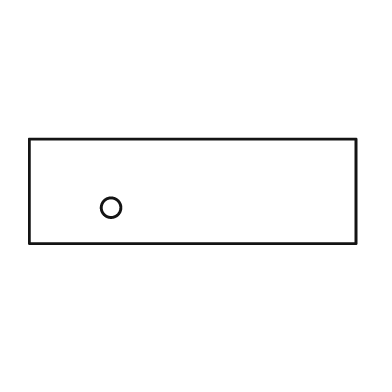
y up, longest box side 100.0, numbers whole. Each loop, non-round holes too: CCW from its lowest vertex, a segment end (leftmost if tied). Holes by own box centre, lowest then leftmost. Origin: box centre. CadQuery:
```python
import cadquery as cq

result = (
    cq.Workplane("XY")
    .moveTo(-50.0, -16.0)
    .lineTo(50.0, -16.0)
    .lineTo(50.0, 16.0)
    .lineTo(-50.0, 16.0)
    .close()
    .moveTo(-25.0, -5.0)
    .circle(3.0)
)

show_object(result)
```